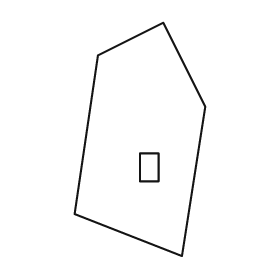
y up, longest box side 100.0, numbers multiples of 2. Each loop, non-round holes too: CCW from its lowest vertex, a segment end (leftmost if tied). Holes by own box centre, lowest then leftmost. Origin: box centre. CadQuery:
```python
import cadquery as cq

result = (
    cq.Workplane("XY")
    .moveTo(18.0, -50.0)
    .lineTo(28.0, 14.0)
    .lineTo(10.0, 50.0)
    .lineTo(-18.0, 36.0)
    .lineTo(-28.0, -32.0)
    .close()
    .moveTo(0.0, -18.0)
    .lineTo(8.0, -18.0)
    .lineTo(8.0, -6.0)
    .lineTo(0.0, -6.0)
    .close()
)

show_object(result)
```